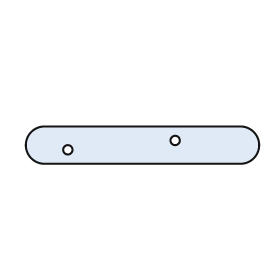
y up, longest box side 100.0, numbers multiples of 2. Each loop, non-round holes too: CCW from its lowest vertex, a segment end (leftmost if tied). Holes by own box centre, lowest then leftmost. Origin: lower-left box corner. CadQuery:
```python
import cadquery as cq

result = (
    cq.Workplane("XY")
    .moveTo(8.0, 0.0)
    .lineTo(92.0, 0.0)
    .threePointArc((100.0, 8.0), (92.0, 16.0))
    .lineTo(8.0, 16.0)
    .threePointArc((0.0, 8.0), (8.0, 0.0))
    .close()
    .moveTo(18.0, 6.0)
    .circle(2.0)
    .moveTo(64.0, 10.0)
    .circle(2.0)
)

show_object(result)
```